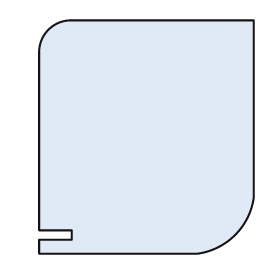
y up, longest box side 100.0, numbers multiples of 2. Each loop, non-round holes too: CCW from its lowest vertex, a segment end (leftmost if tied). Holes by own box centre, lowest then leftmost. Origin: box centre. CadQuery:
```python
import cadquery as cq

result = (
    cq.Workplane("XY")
    .moveTo(-46.0, -50.0)
    .lineTo(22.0, -50.0)
    .threePointArc((38.0, -42.0), (46.0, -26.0))
    .lineTo(46.0, 50.0)
    .lineTo(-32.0, 50.0)
    .threePointArc((-42.0, 46.0), (-46.0, 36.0))
    .lineTo(-46.0, -40.0)
    .lineTo(-32.0, -40.0)
    .lineTo(-32.0, -44.0)
    .lineTo(-46.0, -44.0)
    .close()
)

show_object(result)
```